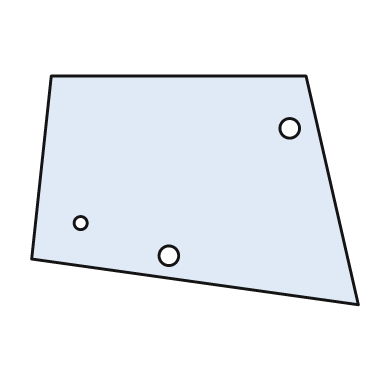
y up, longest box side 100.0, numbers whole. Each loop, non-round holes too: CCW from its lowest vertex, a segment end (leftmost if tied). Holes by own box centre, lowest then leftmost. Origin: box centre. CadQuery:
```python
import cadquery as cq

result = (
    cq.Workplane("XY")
    .moveTo(50.0, -35.0)
    .lineTo(34.0, 35.0)
    .lineTo(-44.0, 35.0)
    .lineTo(-50.0, -21.0)
    .close()
    .moveTo(-8.0, -20.0)
    .circle(3.0)
    .moveTo(-35.0, -10.0)
    .circle(2.0)
    .moveTo(29.0, 19.0)
    .circle(3.0)
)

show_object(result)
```